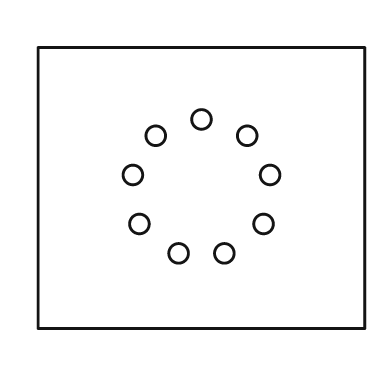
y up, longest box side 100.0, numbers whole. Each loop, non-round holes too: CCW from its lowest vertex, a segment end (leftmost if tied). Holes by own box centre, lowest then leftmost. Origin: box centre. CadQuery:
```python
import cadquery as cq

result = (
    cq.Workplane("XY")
    .moveTo(-50.0, -43.0)
    .lineTo(50.0, -43.0)
    .lineTo(50.0, 43.0)
    .lineTo(-50.0, 43.0)
    .close()
    .moveTo(-7.0, -20.0)
    .circle(3.0)
    .moveTo(7.0, -20.0)
    .circle(3.0)
    .moveTo(-19.0, -11.0)
    .circle(3.0)
    .moveTo(19.0, -11.0)
    .circle(3.0)
    .moveTo(-21.0, 4.0)
    .circle(3.0)
    .moveTo(21.0, 4.0)
    .circle(3.0)
    .moveTo(-14.0, 16.0)
    .circle(3.0)
    .moveTo(14.0, 16.0)
    .circle(3.0)
    .moveTo(0.0, 21.0)
    .circle(3.0)
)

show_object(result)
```